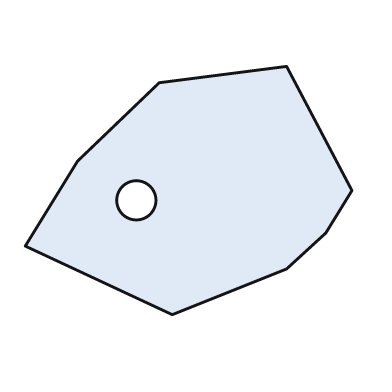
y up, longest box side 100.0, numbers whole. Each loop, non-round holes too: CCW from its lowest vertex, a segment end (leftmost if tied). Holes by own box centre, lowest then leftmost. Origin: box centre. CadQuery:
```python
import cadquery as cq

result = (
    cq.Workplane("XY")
    .moveTo(-5.0, -38.0)
    .lineTo(30.0, -24.0)
    .lineTo(42.0, -13.0)
    .lineTo(50.0, 0.0)
    .lineTo(30.0, 38.0)
    .lineTo(-9.0, 33.0)
    .lineTo(-34.0, 9.0)
    .lineTo(-50.0, -17.0)
    .close()
    .moveTo(-16.0, -3.0)
    .circle(6.0)
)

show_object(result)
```